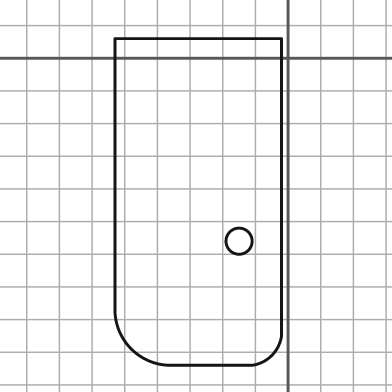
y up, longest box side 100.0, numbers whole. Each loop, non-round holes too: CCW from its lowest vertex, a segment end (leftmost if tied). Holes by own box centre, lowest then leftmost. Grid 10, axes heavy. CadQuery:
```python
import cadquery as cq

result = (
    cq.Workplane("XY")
    .moveTo(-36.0, -94.0)
    .lineTo(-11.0, -94.0)
    .threePointArc((-5.0, -91.0), (-2.0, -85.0))
    .lineTo(-2.0, 6.0)
    .lineTo(-53.0, 6.0)
    .lineTo(-53.0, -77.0)
    .threePointArc((-48.0, -89.0), (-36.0, -94.0))
    .close()
    .moveTo(-15.0, -56.0)
    .circle(4.0)
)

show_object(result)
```